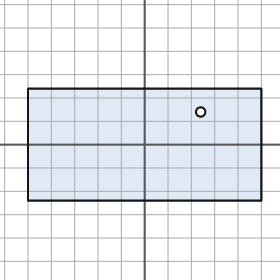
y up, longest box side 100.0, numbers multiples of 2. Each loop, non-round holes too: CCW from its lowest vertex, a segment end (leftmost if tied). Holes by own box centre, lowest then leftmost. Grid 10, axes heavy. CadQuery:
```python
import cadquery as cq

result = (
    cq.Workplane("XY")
    .moveTo(-50.0, -24.0)
    .lineTo(50.0, -24.0)
    .lineTo(50.0, 24.0)
    .lineTo(-50.0, 24.0)
    .close()
    .moveTo(24.0, 14.0)
    .circle(2.0)
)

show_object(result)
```